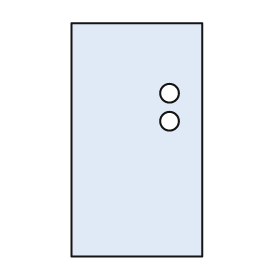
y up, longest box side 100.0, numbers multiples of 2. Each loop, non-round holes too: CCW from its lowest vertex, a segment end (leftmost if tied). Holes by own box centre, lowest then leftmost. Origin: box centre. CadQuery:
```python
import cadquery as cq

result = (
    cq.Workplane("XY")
    .moveTo(-28.0, -50.0)
    .lineTo(28.0, -50.0)
    .lineTo(28.0, 50.0)
    .lineTo(-28.0, 50.0)
    .close()
    .moveTo(14.0, 8.0)
    .circle(4.0)
    .moveTo(14.0, 20.0)
    .circle(4.0)
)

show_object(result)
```